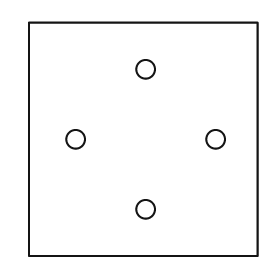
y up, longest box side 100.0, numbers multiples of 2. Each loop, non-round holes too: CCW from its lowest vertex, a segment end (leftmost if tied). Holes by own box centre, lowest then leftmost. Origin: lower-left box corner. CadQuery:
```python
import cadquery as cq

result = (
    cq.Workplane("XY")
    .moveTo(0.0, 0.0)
    .lineTo(98.0, 0.0)
    .lineTo(98.0, 100.0)
    .lineTo(0.0, 100.0)
    .close()
    .moveTo(50.0, 20.0)
    .circle(4.0)
    .moveTo(20.0, 50.0)
    .circle(4.0)
    .moveTo(80.0, 50.0)
    .circle(4.0)
    .moveTo(50.0, 80.0)
    .circle(4.0)
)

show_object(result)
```